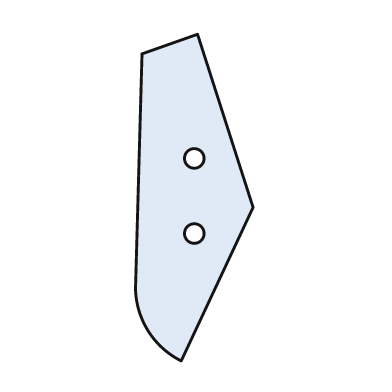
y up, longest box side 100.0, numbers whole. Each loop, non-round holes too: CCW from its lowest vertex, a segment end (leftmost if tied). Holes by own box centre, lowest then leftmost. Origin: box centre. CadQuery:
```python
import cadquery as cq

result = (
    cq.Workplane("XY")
    .moveTo(-4.0, -50.0)
    .lineTo(18.0, -3.0)
    .lineTo(1.0, 50.0)
    .lineTo(-16.0, 44.0)
    .lineTo(-18.0, -28.0)
    .threePointArc((-14.0, -41.0), (-4.0, -50.0))
    .close()
    .moveTo(0.0, -11.0)
    .circle(3.0)
    .moveTo(0.0, 12.0)
    .circle(3.0)
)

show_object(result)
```